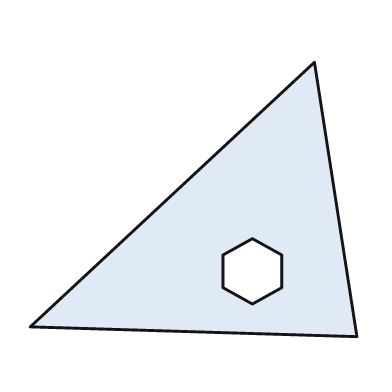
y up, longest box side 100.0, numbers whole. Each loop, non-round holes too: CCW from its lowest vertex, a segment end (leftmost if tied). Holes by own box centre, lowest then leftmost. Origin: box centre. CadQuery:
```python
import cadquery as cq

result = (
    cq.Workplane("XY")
    .moveTo(50.0, -42.0)
    .lineTo(37.0, 42.0)
    .lineTo(-50.0, -39.0)
    .close()
    .moveTo(18.0, -32.0)
    .lineTo(27.0, -27.0)
    .lineTo(27.0, -17.0)
    .lineTo(18.0, -12.0)
    .lineTo(9.0, -17.0)
    .lineTo(9.0, -27.0)
    .close()
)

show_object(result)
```